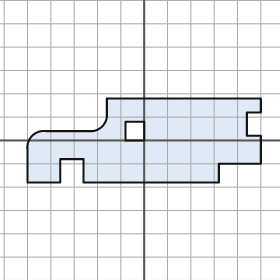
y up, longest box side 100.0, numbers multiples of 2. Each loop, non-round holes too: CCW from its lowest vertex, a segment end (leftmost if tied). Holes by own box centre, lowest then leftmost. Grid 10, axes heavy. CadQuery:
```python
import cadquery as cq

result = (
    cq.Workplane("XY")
    .moveTo(-50.0, -18.0)
    .lineTo(-36.0, -18.0)
    .lineTo(-36.0, -8.0)
    .lineTo(-26.0, -8.0)
    .lineTo(-26.0, -18.0)
    .lineTo(32.0, -18.0)
    .lineTo(32.0, -10.0)
    .lineTo(50.0, -10.0)
    .lineTo(50.0, 2.0)
    .lineTo(44.0, 2.0)
    .lineTo(44.0, 12.0)
    .lineTo(50.0, 12.0)
    .lineTo(50.0, 18.0)
    .lineTo(-16.0, 18.0)
    .lineTo(-16.0, 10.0)
    .threePointArc((-18.0, 6.0), (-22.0, 4.0))
    .lineTo(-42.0, 4.0)
    .threePointArc((-48.0, 2.0), (-50.0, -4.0))
    .close()
    .moveTo(-8.0, 0.0)
    .lineTo(0.0, 0.0)
    .lineTo(0.0, 8.0)
    .lineTo(-8.0, 8.0)
    .close()
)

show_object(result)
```